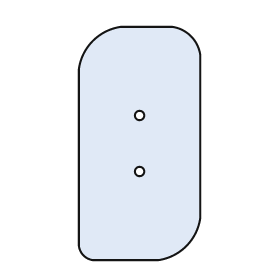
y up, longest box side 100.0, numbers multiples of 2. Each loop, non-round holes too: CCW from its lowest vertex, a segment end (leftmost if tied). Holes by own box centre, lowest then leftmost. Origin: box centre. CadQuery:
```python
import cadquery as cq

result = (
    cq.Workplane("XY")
    .moveTo(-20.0, -50.0)
    .lineTo(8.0, -50.0)
    .threePointArc((20.0, -44.0), (26.0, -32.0))
    .lineTo(26.0, 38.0)
    .threePointArc((22.0, 46.0), (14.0, 50.0))
    .lineTo(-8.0, 50.0)
    .threePointArc((-20.0, 44.0), (-26.0, 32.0))
    .lineTo(-26.0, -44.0)
    .threePointArc((-24.0, -48.0), (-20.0, -50.0))
    .close()
    .moveTo(0.0, -12.0)
    .circle(2.0)
    .moveTo(0.0, 12.0)
    .circle(2.0)
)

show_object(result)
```